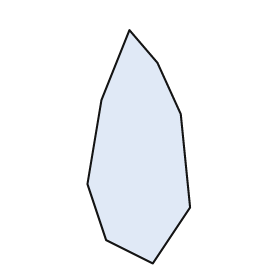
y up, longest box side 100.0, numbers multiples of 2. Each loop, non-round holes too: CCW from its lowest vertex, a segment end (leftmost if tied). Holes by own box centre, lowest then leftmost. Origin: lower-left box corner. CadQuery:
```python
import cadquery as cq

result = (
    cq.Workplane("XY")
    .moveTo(28.0, 0.0)
    .lineTo(44.0, 24.0)
    .lineTo(40.0, 64.0)
    .lineTo(30.0, 86.0)
    .lineTo(18.0, 100.0)
    .lineTo(6.0, 70.0)
    .lineTo(0.0, 34.0)
    .lineTo(8.0, 10.0)
    .close()
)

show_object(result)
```